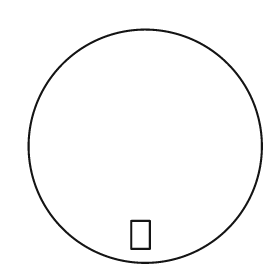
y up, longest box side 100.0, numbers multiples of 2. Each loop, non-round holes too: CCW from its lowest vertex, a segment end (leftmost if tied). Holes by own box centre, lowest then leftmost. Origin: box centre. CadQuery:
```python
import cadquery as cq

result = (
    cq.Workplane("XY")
    .moveTo(0.0, 0.0)
    .circle(50.0)
    .moveTo(-6.0, -44.0)
    .lineTo(2.0, -44.0)
    .lineTo(2.0, -32.0)
    .lineTo(-6.0, -32.0)
    .close()
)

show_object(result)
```